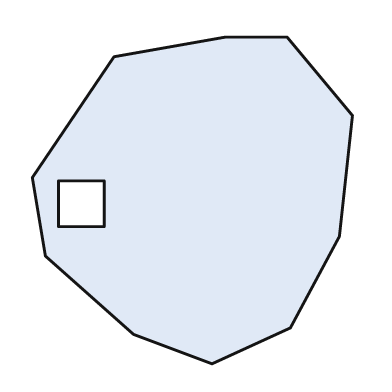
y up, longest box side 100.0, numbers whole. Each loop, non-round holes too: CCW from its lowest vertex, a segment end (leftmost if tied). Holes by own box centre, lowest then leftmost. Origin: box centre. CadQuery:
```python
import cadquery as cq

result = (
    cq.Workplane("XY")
    .moveTo(6.0, -50.0)
    .lineTo(30.0, -39.0)
    .lineTo(45.0, -11.0)
    .lineTo(49.0, 26.0)
    .lineTo(29.0, 50.0)
    .lineTo(10.0, 50.0)
    .lineTo(-24.0, 44.0)
    .lineTo(-49.0, 7.0)
    .lineTo(-45.0, -17.0)
    .lineTo(-18.0, -41.0)
    .close()
    .moveTo(-41.0, -8.0)
    .lineTo(-27.0, -8.0)
    .lineTo(-27.0, 6.0)
    .lineTo(-41.0, 6.0)
    .close()
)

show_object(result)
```